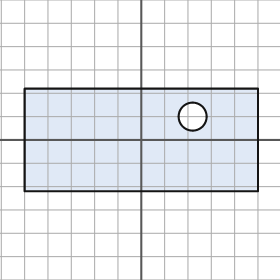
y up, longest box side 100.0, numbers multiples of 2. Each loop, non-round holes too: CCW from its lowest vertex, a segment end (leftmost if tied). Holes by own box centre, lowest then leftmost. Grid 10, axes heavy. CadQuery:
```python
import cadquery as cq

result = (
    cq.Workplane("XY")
    .moveTo(-50.0, -22.0)
    .lineTo(50.0, -22.0)
    .lineTo(50.0, 22.0)
    .lineTo(-50.0, 22.0)
    .close()
    .moveTo(22.0, 10.0)
    .circle(6.0)
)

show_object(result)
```